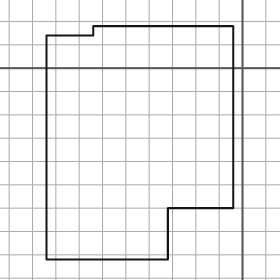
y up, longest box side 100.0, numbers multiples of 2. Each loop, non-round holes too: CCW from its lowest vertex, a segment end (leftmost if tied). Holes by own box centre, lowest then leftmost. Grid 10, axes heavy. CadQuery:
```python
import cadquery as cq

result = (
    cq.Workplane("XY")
    .moveTo(-84.0, -82.0)
    .lineTo(-32.0, -82.0)
    .lineTo(-32.0, -60.0)
    .lineTo(-4.0, -60.0)
    .lineTo(-4.0, 18.0)
    .lineTo(-64.0, 18.0)
    .lineTo(-64.0, 14.0)
    .lineTo(-84.0, 14.0)
    .close()
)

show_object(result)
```